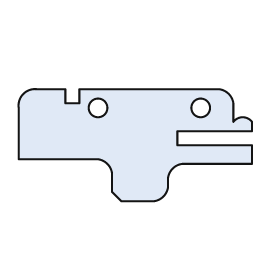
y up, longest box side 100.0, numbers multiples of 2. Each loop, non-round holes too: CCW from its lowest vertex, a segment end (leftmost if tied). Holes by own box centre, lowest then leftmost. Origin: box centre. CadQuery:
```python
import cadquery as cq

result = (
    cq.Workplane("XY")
    .moveTo(-6.0, -24.0)
    .lineTo(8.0, -24.0)
    .threePointArc((12.0, -22.0), (14.0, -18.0))
    .lineTo(14.0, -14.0)
    .threePointArc((16.0, -10.0), (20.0, -8.0))
    .lineTo(50.0, -8.0)
    .lineTo(50.0, 0.0)
    .lineTo(18.0, 0.0)
    .lineTo(18.0, 6.0)
    .lineTo(50.0, 6.0)
    .lineTo(50.0, 10.0)
    .threePointArc((46.0, 12.0), (42.0, 10.0))
    .lineTo(42.0, 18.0)
    .threePointArc((40.0, 22.0), (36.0, 24.0))
    .lineTo(-24.0, 24.0)
    .lineTo(-24.0, 18.0)
    .lineTo(-30.0, 18.0)
    .lineTo(-30.0, 24.0)
    .lineTo(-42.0, 24.0)
    .threePointArc((-48.0, 22.0), (-50.0, 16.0))
    .lineTo(-50.0, -6.0)
    .lineTo(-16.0, -6.0)
    .threePointArc((-12.0, -8.0), (-10.0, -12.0))
    .lineTo(-10.0, -20.0)
    .close()
    .moveTo(-16.0, 16.0)
    .circle(4.0)
    .moveTo(28.0, 16.0)
    .circle(4.0)
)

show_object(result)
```